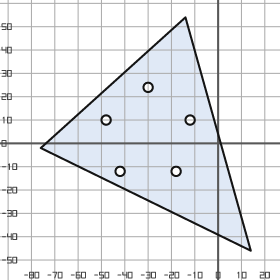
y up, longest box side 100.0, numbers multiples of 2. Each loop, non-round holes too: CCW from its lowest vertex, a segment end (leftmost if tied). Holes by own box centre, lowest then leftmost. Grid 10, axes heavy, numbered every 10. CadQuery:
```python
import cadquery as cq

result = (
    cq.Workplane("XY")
    .moveTo(14.0, -46.0)
    .lineTo(-14.0, 54.0)
    .lineTo(-76.0, -2.0)
    .close()
    .moveTo(-42.0, -12.0)
    .circle(2.0)
    .moveTo(-18.0, -12.0)
    .circle(2.0)
    .moveTo(-48.0, 10.0)
    .circle(2.0)
    .moveTo(-12.0, 10.0)
    .circle(2.0)
    .moveTo(-30.0, 24.0)
    .circle(2.0)
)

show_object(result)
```